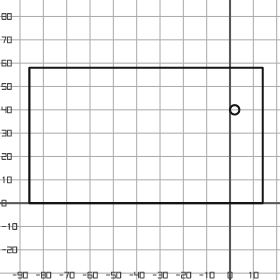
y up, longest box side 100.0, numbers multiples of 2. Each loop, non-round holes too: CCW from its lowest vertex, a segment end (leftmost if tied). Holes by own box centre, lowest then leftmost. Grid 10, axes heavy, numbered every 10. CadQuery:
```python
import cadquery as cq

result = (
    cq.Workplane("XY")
    .moveTo(-86.0, 0.0)
    .lineTo(14.0, 0.0)
    .lineTo(14.0, 58.0)
    .lineTo(-86.0, 58.0)
    .close()
    .moveTo(2.0, 40.0)
    .circle(2.0)
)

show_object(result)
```